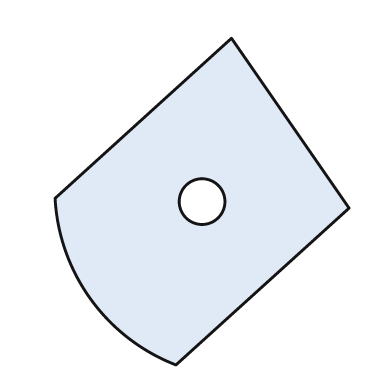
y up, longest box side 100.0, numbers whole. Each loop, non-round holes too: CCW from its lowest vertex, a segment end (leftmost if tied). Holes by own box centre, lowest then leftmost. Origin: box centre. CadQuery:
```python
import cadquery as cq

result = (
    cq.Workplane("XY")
    .moveTo(-8.0, -50.0)
    .lineTo(45.0, -2.0)
    .lineTo(9.0, 50.0)
    .lineTo(-45.0, 1.0)
    .threePointArc((-34.0, -30.0), (-8.0, -50.0))
    .close()
    .moveTo(0.0, 0.0)
    .circle(7.0)
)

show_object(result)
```